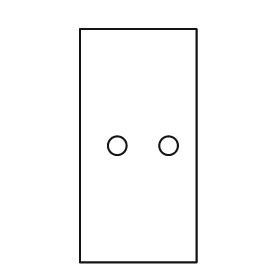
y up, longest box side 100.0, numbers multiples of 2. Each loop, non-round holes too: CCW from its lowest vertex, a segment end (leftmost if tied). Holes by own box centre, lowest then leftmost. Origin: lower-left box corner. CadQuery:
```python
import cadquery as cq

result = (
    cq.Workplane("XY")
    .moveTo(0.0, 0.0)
    .lineTo(50.0, 0.0)
    .lineTo(50.0, 100.0)
    .lineTo(0.0, 100.0)
    .close()
    .moveTo(16.0, 50.0)
    .circle(4.0)
    .moveTo(38.0, 50.0)
    .circle(4.0)
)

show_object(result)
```